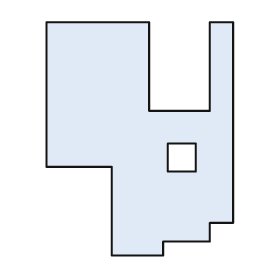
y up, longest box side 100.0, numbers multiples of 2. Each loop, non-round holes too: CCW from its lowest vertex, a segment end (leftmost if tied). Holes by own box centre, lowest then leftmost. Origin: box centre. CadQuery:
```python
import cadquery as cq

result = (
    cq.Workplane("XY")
    .moveTo(-12.0, -50.0)
    .lineTo(10.0, -50.0)
    .lineTo(10.0, -44.0)
    .lineTo(30.0, -44.0)
    .lineTo(30.0, -36.0)
    .lineTo(40.0, -36.0)
    .lineTo(40.0, 50.0)
    .lineTo(30.0, 50.0)
    .lineTo(30.0, 12.0)
    .lineTo(4.0, 12.0)
    .lineTo(4.0, 50.0)
    .lineTo(-40.0, 50.0)
    .lineTo(-40.0, -12.0)
    .lineTo(-12.0, -12.0)
    .close()
    .moveTo(12.0, -14.0)
    .lineTo(24.0, -14.0)
    .lineTo(24.0, -2.0)
    .lineTo(12.0, -2.0)
    .close()
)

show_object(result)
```